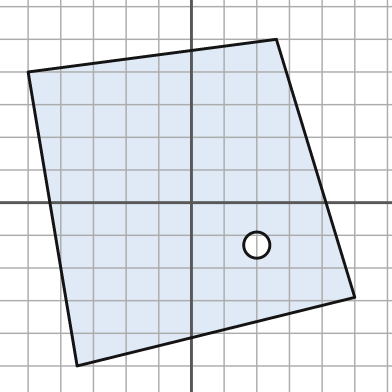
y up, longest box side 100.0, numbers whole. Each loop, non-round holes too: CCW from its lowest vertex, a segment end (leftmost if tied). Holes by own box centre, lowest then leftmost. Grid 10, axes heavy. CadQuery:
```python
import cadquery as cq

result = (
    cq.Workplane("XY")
    .moveTo(-35.0, -50.0)
    .lineTo(50.0, -29.0)
    .lineTo(26.0, 50.0)
    .lineTo(-50.0, 40.0)
    .close()
    .moveTo(20.0, -13.0)
    .circle(4.0)
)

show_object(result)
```